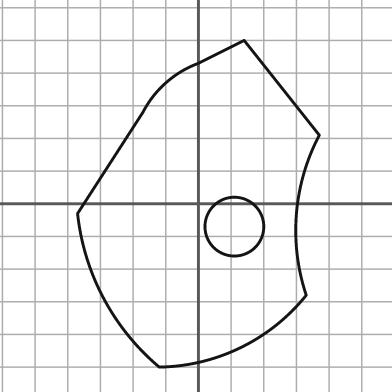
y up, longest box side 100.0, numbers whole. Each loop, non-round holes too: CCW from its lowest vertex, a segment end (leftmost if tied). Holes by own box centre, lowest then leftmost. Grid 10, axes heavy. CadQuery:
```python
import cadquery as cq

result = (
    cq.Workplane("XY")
    .moveTo(-12.0, -50.0)
    .threePointArc((13.0, -44.0), (33.0, -28.0))
    .threePointArc((30.0, -3.0), (37.0, 21.0))
    .lineTo(14.0, 50.0)
    .lineTo(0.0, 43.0)
    .threePointArc((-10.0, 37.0), (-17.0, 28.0))
    .lineTo(-37.0, -3.0)
    .threePointArc((-29.0, -29.0), (-12.0, -50.0))
    .close()
    .moveTo(11.0, -7.0)
    .circle(9.0)
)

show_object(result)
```